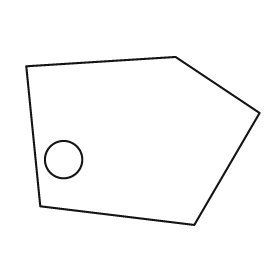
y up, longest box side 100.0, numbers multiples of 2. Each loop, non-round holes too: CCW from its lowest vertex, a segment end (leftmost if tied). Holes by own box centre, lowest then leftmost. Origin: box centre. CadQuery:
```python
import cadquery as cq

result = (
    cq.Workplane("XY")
    .moveTo(22.0, -36.0)
    .lineTo(50.0, 12.0)
    .lineTo(14.0, 36.0)
    .lineTo(-50.0, 32.0)
    .lineTo(-44.0, -28.0)
    .close()
    .moveTo(-34.0, -8.0)
    .circle(8.0)
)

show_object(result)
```